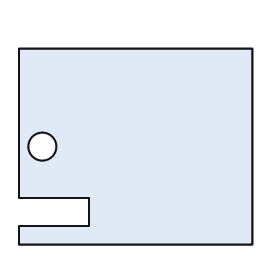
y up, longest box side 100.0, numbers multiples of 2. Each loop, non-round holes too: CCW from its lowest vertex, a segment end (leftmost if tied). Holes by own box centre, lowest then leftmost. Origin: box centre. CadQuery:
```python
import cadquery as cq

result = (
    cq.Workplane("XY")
    .moveTo(-50.0, -42.0)
    .lineTo(50.0, -42.0)
    .lineTo(50.0, 42.0)
    .lineTo(-50.0, 42.0)
    .lineTo(-50.0, -22.0)
    .lineTo(-20.0, -22.0)
    .lineTo(-20.0, -34.0)
    .lineTo(-50.0, -34.0)
    .close()
    .moveTo(-40.0, 0.0)
    .circle(6.0)
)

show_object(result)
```